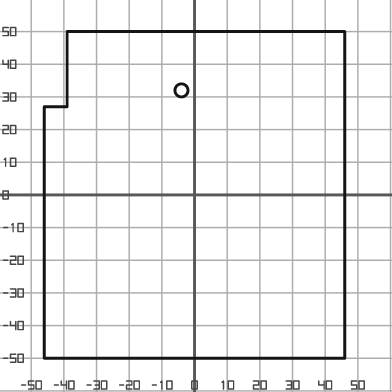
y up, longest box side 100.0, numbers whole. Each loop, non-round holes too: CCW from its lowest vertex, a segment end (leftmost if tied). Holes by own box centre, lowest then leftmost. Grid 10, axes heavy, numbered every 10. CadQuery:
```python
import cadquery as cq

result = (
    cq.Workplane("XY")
    .moveTo(-46.0, -50.0)
    .lineTo(46.0, -50.0)
    .lineTo(46.0, 50.0)
    .lineTo(-39.0, 50.0)
    .lineTo(-39.0, 27.0)
    .lineTo(-46.0, 27.0)
    .close()
    .moveTo(-4.0, 32.0)
    .circle(2.0)
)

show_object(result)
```